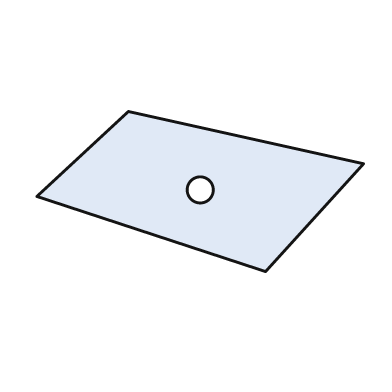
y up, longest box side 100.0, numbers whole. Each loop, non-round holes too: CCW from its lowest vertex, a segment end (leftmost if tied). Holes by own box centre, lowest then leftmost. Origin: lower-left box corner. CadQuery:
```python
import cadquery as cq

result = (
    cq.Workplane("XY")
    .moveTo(70.0, 0.0)
    .lineTo(100.0, 33.0)
    .lineTo(28.0, 49.0)
    .lineTo(0.0, 23.0)
    .close()
    .moveTo(50.0, 25.0)
    .circle(4.0)
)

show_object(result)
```